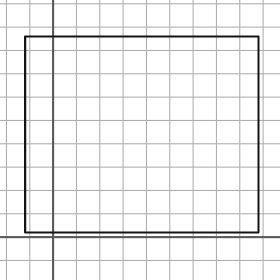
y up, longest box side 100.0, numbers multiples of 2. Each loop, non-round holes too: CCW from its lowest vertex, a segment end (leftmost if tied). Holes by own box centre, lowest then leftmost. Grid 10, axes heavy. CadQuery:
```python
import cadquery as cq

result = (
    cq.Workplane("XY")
    .moveTo(-12.0, 2.0)
    .lineTo(88.0, 2.0)
    .lineTo(88.0, 86.0)
    .lineTo(-12.0, 86.0)
    .close()
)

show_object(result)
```